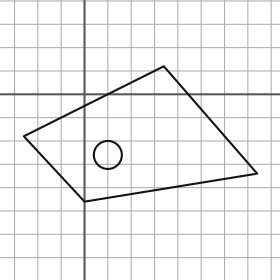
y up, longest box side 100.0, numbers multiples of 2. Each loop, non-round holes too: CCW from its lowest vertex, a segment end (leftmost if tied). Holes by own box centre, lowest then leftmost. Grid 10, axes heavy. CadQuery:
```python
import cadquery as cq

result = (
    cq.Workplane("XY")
    .moveTo(0.0, -46.0)
    .lineTo(74.0, -34.0)
    .lineTo(34.0, 12.0)
    .lineTo(-26.0, -18.0)
    .close()
    .moveTo(10.0, -26.0)
    .circle(6.0)
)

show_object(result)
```